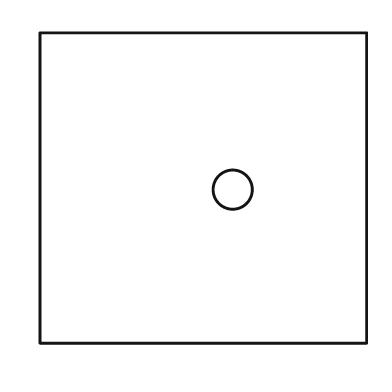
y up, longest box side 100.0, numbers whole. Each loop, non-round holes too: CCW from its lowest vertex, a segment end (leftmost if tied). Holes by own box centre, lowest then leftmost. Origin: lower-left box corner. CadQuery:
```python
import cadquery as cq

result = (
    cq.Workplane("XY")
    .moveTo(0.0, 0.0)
    .lineTo(100.0, 0.0)
    .lineTo(100.0, 95.0)
    .lineTo(0.0, 95.0)
    .close()
    .moveTo(59.0, 47.0)
    .circle(6.0)
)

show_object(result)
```